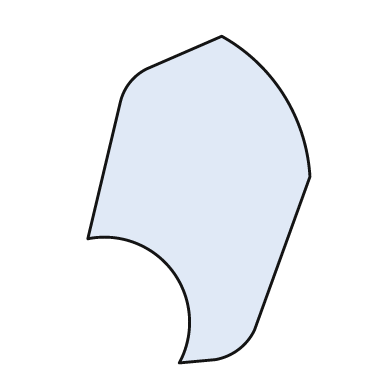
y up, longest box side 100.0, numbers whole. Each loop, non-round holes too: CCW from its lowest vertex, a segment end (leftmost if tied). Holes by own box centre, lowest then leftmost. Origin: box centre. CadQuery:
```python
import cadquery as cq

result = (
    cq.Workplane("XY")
    .moveTo(-6.0, -50.0)
    .lineTo(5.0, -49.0)
    .threePointArc((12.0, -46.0), (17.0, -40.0))
    .lineTo(34.0, 7.0)
    .threePointArc((26.0, 32.0), (7.0, 50.0))
    .lineTo(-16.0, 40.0)
    .threePointArc((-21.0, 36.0), (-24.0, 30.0))
    .lineTo(-34.0, -12.0)
    .threePointArc((-8.0, -22.0), (-6.0, -50.0))
    .close()
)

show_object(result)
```